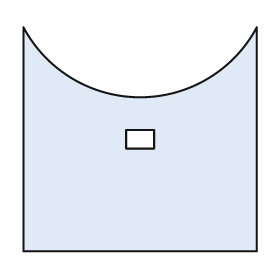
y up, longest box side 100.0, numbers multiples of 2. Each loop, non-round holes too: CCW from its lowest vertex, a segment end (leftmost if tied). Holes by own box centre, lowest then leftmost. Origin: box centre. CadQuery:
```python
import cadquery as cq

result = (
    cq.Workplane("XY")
    .moveTo(-50.0, -48.0)
    .lineTo(50.0, -48.0)
    .lineTo(50.0, 48.0)
    .threePointArc((0.0, 18.0), (-50.0, 48.0))
    .close()
    .moveTo(-6.0, -4.0)
    .lineTo(6.0, -4.0)
    .lineTo(6.0, 4.0)
    .lineTo(-6.0, 4.0)
    .close()
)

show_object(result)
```